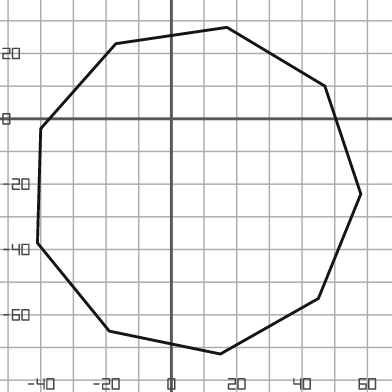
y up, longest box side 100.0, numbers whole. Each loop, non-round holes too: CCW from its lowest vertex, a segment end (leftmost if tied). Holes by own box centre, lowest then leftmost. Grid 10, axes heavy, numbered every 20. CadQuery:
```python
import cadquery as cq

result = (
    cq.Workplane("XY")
    .moveTo(15.0, -72.0)
    .lineTo(45.0, -55.0)
    .lineTo(58.0, -23.0)
    .lineTo(47.0, 10.0)
    .lineTo(17.0, 28.0)
    .lineTo(-17.0, 23.0)
    .lineTo(-40.0, -3.0)
    .lineTo(-41.0, -38.0)
    .lineTo(-19.0, -65.0)
    .close()
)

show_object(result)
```